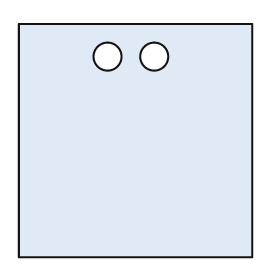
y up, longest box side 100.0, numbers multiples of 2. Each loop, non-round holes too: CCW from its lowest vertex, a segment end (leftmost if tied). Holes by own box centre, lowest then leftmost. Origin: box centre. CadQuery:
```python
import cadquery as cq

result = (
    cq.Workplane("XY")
    .moveTo(-50.0, -50.0)
    .lineTo(50.0, -50.0)
    .lineTo(50.0, 50.0)
    .lineTo(-50.0, 50.0)
    .close()
    .moveTo(-12.0, 36.0)
    .circle(6.0)
    .moveTo(8.0, 36.0)
    .circle(6.0)
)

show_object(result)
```